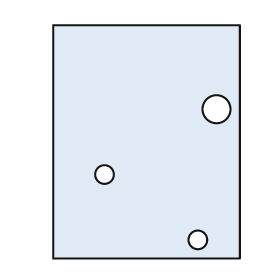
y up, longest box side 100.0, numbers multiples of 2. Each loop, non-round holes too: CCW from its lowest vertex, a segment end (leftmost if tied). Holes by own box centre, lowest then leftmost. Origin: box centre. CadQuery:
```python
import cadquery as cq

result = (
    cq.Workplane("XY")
    .moveTo(-40.0, -50.0)
    .lineTo(40.0, -50.0)
    .lineTo(40.0, 50.0)
    .lineTo(-40.0, 50.0)
    .close()
    .moveTo(22.0, -42.0)
    .circle(4.0)
    .moveTo(-18.0, -14.0)
    .circle(4.0)
    .moveTo(30.0, 14.0)
    .circle(6.0)
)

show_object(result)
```